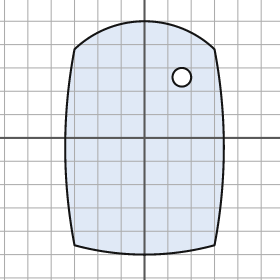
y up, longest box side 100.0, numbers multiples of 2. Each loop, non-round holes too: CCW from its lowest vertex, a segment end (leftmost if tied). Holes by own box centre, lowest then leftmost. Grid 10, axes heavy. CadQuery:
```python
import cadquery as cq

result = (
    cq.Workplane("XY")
    .moveTo(-30.0, -46.0)
    .threePointArc((0.0, -50.0), (30.0, -46.0))
    .threePointArc((34.0, -4.0), (30.0, 38.0))
    .threePointArc((0.0, 50.0), (-30.0, 38.0))
    .threePointArc((-34.0, -4.0), (-30.0, -46.0))
    .close()
    .moveTo(16.0, 26.0)
    .circle(4.0)
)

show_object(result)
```